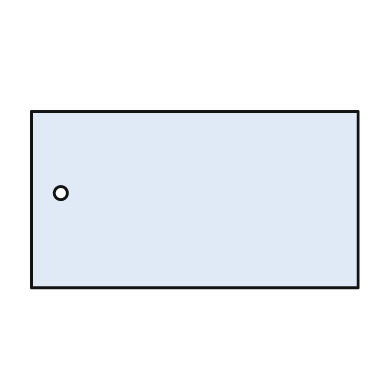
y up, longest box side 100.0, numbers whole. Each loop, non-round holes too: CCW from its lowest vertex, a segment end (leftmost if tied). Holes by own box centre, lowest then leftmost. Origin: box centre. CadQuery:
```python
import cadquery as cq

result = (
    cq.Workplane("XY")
    .moveTo(-50.0, -27.0)
    .lineTo(50.0, -27.0)
    .lineTo(50.0, 27.0)
    .lineTo(-50.0, 27.0)
    .close()
    .moveTo(-41.0, 2.0)
    .circle(2.0)
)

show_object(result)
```